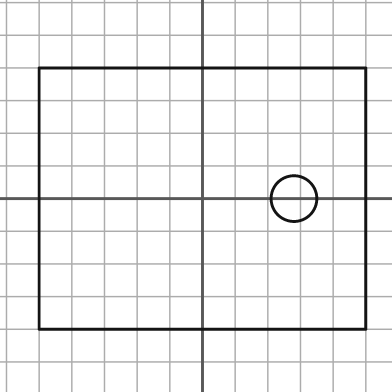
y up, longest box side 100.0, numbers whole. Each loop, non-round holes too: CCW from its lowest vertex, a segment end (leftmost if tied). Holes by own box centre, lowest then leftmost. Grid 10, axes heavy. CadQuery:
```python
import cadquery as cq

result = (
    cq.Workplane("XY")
    .moveTo(-50.0, -40.0)
    .lineTo(50.0, -40.0)
    .lineTo(50.0, 40.0)
    .lineTo(-50.0, 40.0)
    .close()
    .moveTo(28.0, 0.0)
    .circle(7.0)
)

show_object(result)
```